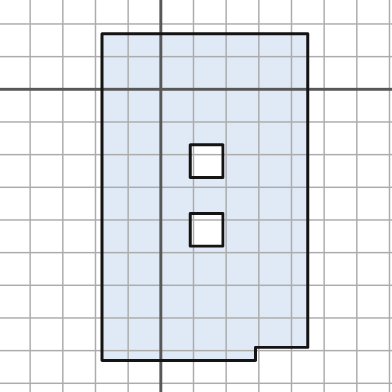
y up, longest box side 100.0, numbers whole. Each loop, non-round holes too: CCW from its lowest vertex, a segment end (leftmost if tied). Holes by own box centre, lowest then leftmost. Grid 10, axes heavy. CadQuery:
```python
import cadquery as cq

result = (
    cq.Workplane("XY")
    .moveTo(-18.0, -83.0)
    .lineTo(29.0, -83.0)
    .lineTo(29.0, -79.0)
    .lineTo(45.0, -79.0)
    .lineTo(45.0, 17.0)
    .lineTo(-18.0, 17.0)
    .close()
    .moveTo(9.0, -48.0)
    .lineTo(19.0, -48.0)
    .lineTo(19.0, -38.0)
    .lineTo(9.0, -38.0)
    .close()
    .moveTo(9.0, -27.0)
    .lineTo(19.0, -27.0)
    .lineTo(19.0, -17.0)
    .lineTo(9.0, -17.0)
    .close()
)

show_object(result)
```